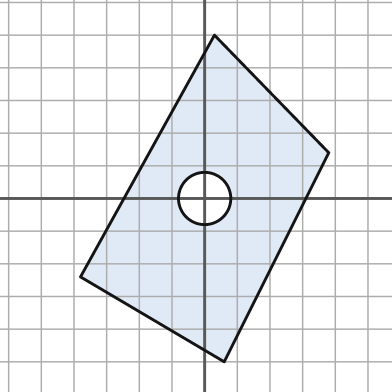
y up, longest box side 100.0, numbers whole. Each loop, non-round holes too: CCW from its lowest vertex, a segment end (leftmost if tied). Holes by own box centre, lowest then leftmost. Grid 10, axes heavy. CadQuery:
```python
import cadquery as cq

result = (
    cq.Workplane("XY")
    .moveTo(6.0, -50.0)
    .lineTo(38.0, 14.0)
    .lineTo(3.0, 50.0)
    .lineTo(-38.0, -24.0)
    .close()
    .moveTo(0.0, 0.0)
    .circle(8.0)
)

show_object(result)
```